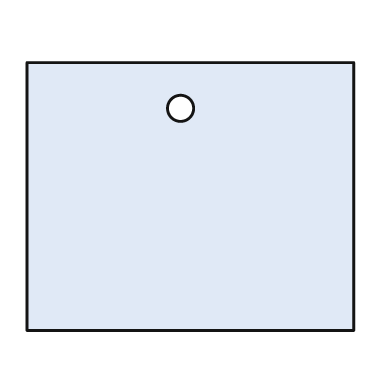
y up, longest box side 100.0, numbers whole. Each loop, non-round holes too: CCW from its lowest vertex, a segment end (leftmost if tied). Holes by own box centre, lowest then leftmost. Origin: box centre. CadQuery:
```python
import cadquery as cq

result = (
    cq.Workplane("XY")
    .moveTo(-50.0, -41.0)
    .lineTo(50.0, -41.0)
    .lineTo(50.0, 41.0)
    .lineTo(-50.0, 41.0)
    .close()
    .moveTo(-3.0, 27.0)
    .circle(4.0)
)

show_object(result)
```